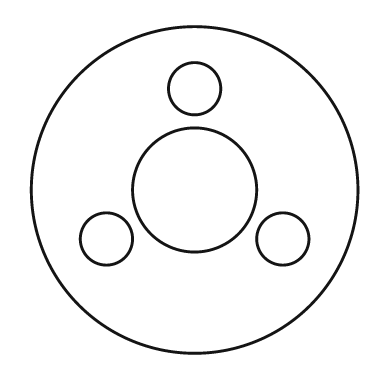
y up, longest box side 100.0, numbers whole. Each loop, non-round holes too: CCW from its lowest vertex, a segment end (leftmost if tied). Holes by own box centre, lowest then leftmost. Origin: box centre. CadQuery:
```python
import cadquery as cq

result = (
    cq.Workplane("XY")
    .moveTo(0.0, 0.0)
    .circle(50.0)
    .moveTo(-27.0, -15.0)
    .circle(8.0)
    .moveTo(27.0, -15.0)
    .circle(8.0)
    .moveTo(0.0, 0.0)
    .circle(19.0)
    .moveTo(0.0, 31.0)
    .circle(8.0)
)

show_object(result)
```